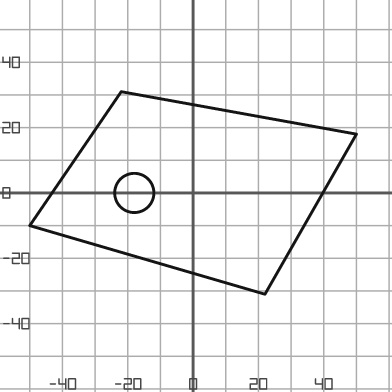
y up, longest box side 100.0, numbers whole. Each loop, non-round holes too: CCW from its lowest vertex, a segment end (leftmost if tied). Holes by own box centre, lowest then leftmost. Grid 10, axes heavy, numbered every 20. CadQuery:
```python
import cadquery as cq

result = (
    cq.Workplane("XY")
    .moveTo(22.0, -31.0)
    .lineTo(50.0, 18.0)
    .lineTo(-22.0, 31.0)
    .lineTo(-50.0, -10.0)
    .close()
    .moveTo(-18.0, 0.0)
    .circle(6.0)
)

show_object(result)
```